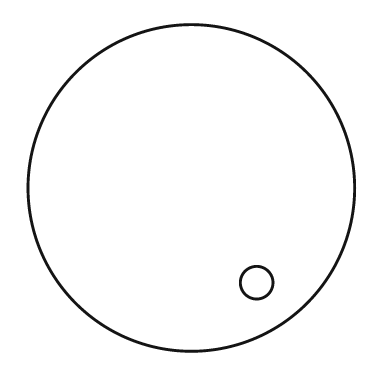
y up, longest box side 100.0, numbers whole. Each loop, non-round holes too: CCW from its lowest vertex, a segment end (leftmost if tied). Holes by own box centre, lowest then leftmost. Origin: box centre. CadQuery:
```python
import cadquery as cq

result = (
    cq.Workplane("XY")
    .moveTo(0.0, 0.0)
    .circle(50.0)
    .moveTo(20.0, -29.0)
    .circle(5.0)
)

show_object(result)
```